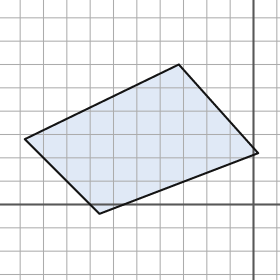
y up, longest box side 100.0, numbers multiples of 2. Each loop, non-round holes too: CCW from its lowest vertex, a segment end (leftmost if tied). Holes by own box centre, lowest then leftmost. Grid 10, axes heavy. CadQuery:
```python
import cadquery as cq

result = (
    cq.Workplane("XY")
    .moveTo(-66.0, -4.0)
    .lineTo(2.0, 22.0)
    .lineTo(-32.0, 60.0)
    .lineTo(-98.0, 28.0)
    .close()
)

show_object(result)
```